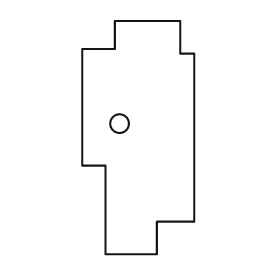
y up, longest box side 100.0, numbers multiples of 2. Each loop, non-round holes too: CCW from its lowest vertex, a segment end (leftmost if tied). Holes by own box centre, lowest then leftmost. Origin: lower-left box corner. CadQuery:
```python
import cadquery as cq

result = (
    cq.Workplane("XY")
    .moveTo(10.0, 0.0)
    .lineTo(32.0, 0.0)
    .lineTo(32.0, 14.0)
    .lineTo(48.0, 14.0)
    .lineTo(48.0, 86.0)
    .lineTo(42.0, 86.0)
    .lineTo(42.0, 100.0)
    .lineTo(14.0, 100.0)
    .lineTo(14.0, 88.0)
    .lineTo(0.0, 88.0)
    .lineTo(0.0, 38.0)
    .lineTo(10.0, 38.0)
    .close()
    .moveTo(16.0, 56.0)
    .circle(4.0)
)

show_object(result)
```